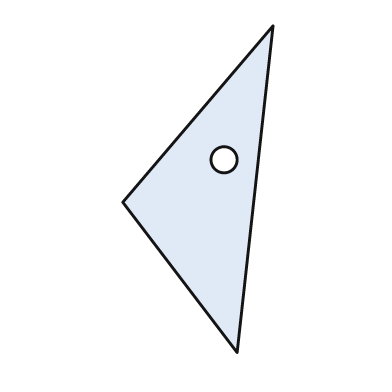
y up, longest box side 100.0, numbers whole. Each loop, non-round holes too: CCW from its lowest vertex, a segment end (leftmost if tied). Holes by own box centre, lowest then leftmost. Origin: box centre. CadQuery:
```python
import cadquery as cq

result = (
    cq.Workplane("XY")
    .moveTo(12.0, -50.0)
    .lineTo(23.0, 50.0)
    .lineTo(-23.0, -4.0)
    .close()
    .moveTo(8.0, 9.0)
    .circle(4.0)
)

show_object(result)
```